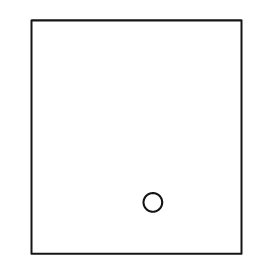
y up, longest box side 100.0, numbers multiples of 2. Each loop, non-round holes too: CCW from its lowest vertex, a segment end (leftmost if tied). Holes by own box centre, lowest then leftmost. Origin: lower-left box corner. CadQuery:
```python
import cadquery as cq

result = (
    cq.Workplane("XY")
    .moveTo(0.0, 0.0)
    .lineTo(90.0, 0.0)
    .lineTo(90.0, 100.0)
    .lineTo(0.0, 100.0)
    .close()
    .moveTo(52.0, 22.0)
    .circle(4.0)
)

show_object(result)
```